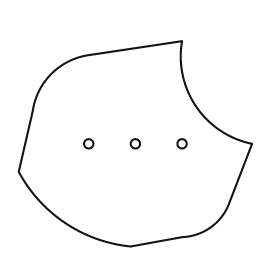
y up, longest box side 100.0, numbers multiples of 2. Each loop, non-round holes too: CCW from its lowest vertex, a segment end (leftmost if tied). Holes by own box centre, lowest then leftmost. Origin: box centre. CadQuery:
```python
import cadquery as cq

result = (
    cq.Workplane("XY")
    .moveTo(-2.0, -44.0)
    .lineTo(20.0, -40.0)
    .threePointArc((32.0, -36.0), (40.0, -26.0))
    .lineTo(50.0, 0.0)
    .threePointArc((26.0, 16.0), (20.0, 44.0))
    .lineTo(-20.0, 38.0)
    .threePointArc((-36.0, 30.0), (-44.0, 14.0))
    .lineTo(-50.0, -12.0)
    .threePointArc((-30.0, -34.0), (-2.0, -44.0))
    .close()
    .moveTo(-20.0, 0.0)
    .circle(2.0)
    .moveTo(0.0, 0.0)
    .circle(2.0)
    .moveTo(20.0, 0.0)
    .circle(2.0)
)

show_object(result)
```